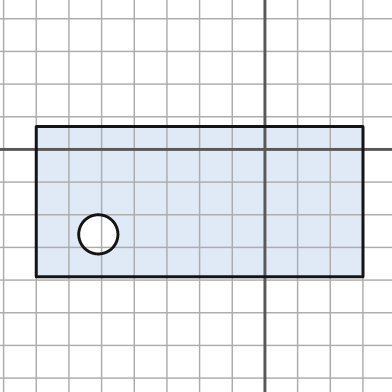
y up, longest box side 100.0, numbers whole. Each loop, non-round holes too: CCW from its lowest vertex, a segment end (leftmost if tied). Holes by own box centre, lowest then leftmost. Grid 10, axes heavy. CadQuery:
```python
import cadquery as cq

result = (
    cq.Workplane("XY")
    .moveTo(-70.0, -39.0)
    .lineTo(30.0, -39.0)
    .lineTo(30.0, 7.0)
    .lineTo(-70.0, 7.0)
    .close()
    .moveTo(-51.0, -26.0)
    .circle(6.0)
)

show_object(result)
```